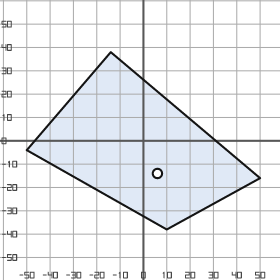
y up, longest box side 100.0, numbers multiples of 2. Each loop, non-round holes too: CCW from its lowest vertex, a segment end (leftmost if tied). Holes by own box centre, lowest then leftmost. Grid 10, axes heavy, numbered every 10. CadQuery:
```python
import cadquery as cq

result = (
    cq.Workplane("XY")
    .moveTo(10.0, -38.0)
    .lineTo(50.0, -16.0)
    .lineTo(-14.0, 38.0)
    .lineTo(-50.0, -4.0)
    .close()
    .moveTo(6.0, -14.0)
    .circle(2.0)
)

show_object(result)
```